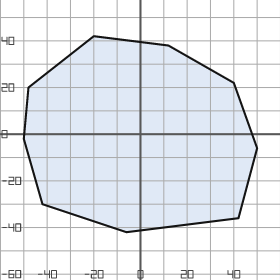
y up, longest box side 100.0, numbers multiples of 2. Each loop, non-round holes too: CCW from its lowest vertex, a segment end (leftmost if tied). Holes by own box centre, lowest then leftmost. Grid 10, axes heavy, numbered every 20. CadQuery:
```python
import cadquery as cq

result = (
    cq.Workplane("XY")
    .moveTo(-6.0, -42.0)
    .lineTo(42.0, -36.0)
    .lineTo(50.0, -6.0)
    .lineTo(40.0, 22.0)
    .lineTo(12.0, 38.0)
    .lineTo(-20.0, 42.0)
    .lineTo(-48.0, 20.0)
    .lineTo(-50.0, -2.0)
    .lineTo(-42.0, -30.0)
    .close()
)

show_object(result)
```